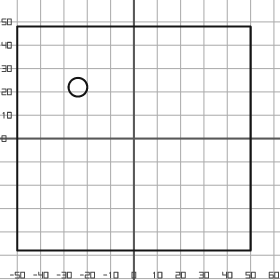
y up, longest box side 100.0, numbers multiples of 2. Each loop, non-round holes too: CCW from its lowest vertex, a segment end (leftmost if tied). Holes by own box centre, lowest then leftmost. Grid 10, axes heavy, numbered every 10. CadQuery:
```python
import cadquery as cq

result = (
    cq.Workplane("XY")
    .moveTo(-50.0, -48.0)
    .lineTo(50.0, -48.0)
    .lineTo(50.0, 48.0)
    .lineTo(-50.0, 48.0)
    .close()
    .moveTo(-24.0, 22.0)
    .circle(4.0)
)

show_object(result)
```